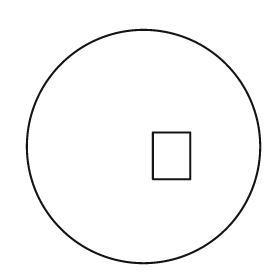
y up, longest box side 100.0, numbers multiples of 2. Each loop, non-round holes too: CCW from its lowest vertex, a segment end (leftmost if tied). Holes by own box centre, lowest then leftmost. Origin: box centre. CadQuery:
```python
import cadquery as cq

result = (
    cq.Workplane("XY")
    .moveTo(0.0, 0.0)
    .circle(50.0)
    .moveTo(4.0, -14.0)
    .lineTo(20.0, -14.0)
    .lineTo(20.0, 6.0)
    .lineTo(4.0, 6.0)
    .close()
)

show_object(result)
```